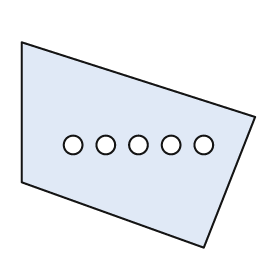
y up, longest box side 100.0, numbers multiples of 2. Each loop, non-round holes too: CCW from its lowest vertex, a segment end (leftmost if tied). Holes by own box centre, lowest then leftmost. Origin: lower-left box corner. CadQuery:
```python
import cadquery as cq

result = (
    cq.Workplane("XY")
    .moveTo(78.0, 0.0)
    .lineTo(100.0, 56.0)
    .lineTo(0.0, 88.0)
    .lineTo(0.0, 28.0)
    .close()
    .moveTo(22.0, 44.0)
    .circle(4.0)
    .moveTo(36.0, 44.0)
    .circle(4.0)
    .moveTo(50.0, 44.0)
    .circle(4.0)
    .moveTo(64.0, 44.0)
    .circle(4.0)
    .moveTo(78.0, 44.0)
    .circle(4.0)
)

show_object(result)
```